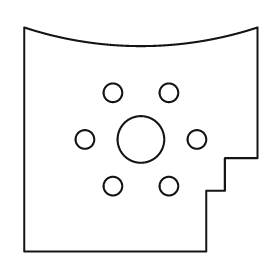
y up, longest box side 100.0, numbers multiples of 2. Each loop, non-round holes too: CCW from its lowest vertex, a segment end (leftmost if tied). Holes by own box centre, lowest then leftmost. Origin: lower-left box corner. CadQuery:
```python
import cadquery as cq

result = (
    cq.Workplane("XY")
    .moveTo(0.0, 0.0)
    .lineTo(78.0, 0.0)
    .lineTo(78.0, 26.0)
    .lineTo(86.0, 26.0)
    .lineTo(86.0, 40.0)
    .lineTo(100.0, 40.0)
    .lineTo(100.0, 96.0)
    .threePointArc((50.0, 88.0), (0.0, 96.0))
    .close()
    .moveTo(38.0, 28.0)
    .circle(4.0)
    .moveTo(62.0, 28.0)
    .circle(4.0)
    .moveTo(26.0, 48.0)
    .circle(4.0)
    .moveTo(50.0, 48.0)
    .circle(10.0)
    .moveTo(74.0, 48.0)
    .circle(4.0)
    .moveTo(38.0, 68.0)
    .circle(4.0)
    .moveTo(62.0, 68.0)
    .circle(4.0)
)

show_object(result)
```